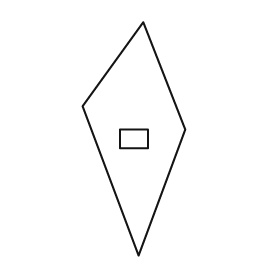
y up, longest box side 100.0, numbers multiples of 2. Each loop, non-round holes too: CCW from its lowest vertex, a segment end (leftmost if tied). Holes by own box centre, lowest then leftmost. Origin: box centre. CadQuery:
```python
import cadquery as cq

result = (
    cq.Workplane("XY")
    .moveTo(2.0, -50.0)
    .lineTo(22.0, 4.0)
    .lineTo(4.0, 50.0)
    .lineTo(-22.0, 14.0)
    .close()
    .moveTo(-6.0, -4.0)
    .lineTo(6.0, -4.0)
    .lineTo(6.0, 4.0)
    .lineTo(-6.0, 4.0)
    .close()
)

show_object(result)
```